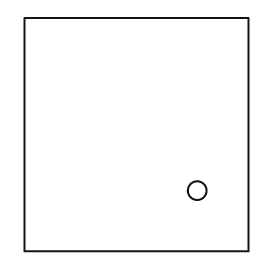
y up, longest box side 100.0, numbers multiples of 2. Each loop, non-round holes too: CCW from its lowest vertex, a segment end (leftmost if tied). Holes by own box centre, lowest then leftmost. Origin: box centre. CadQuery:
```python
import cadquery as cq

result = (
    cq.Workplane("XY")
    .moveTo(-48.0, -50.0)
    .lineTo(48.0, -50.0)
    .lineTo(48.0, 50.0)
    .lineTo(-48.0, 50.0)
    .close()
    .moveTo(26.0, -24.0)
    .circle(4.0)
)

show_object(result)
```